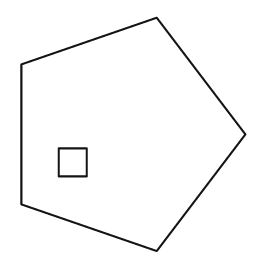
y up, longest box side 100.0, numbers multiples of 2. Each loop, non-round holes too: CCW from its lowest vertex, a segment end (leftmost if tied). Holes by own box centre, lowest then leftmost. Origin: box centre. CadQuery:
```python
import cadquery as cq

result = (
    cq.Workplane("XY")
    .moveTo(10.0, -50.0)
    .lineTo(48.0, 0.0)
    .lineTo(10.0, 50.0)
    .lineTo(-48.0, 30.0)
    .lineTo(-48.0, -30.0)
    .close()
    .moveTo(-32.0, -18.0)
    .lineTo(-20.0, -18.0)
    .lineTo(-20.0, -6.0)
    .lineTo(-32.0, -6.0)
    .close()
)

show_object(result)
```